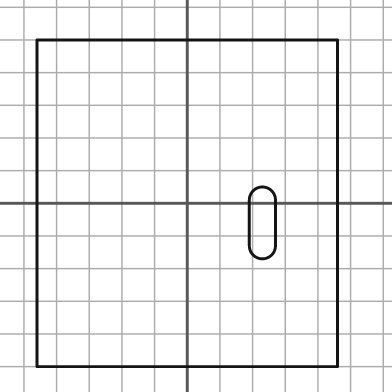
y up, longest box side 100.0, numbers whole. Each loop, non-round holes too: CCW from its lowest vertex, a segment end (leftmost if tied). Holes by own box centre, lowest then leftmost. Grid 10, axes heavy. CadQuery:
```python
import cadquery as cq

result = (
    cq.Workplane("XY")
    .moveTo(-46.0, -50.0)
    .lineTo(46.0, -50.0)
    .lineTo(46.0, 50.0)
    .lineTo(-46.0, 50.0)
    .close()
    .moveTo(19.0, -13.0)
    .threePointArc((23.0, -17.0), (27.0, -13.0))
    .lineTo(27.0, 1.0)
    .threePointArc((23.0, 5.0), (19.0, 1.0))
    .close()
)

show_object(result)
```